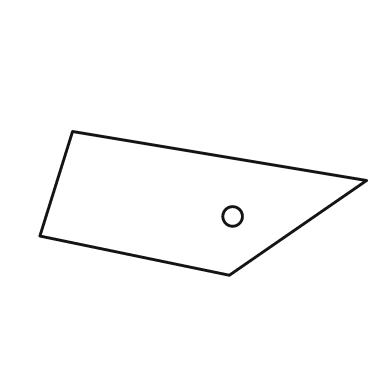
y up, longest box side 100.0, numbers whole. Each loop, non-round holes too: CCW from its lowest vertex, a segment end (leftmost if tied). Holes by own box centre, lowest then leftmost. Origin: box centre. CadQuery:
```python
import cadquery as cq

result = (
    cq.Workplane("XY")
    .moveTo(8.0, -22.0)
    .lineTo(50.0, 7.0)
    .lineTo(-40.0, 22.0)
    .lineTo(-50.0, -10.0)
    .close()
    .moveTo(9.0, -4.0)
    .circle(3.0)
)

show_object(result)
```